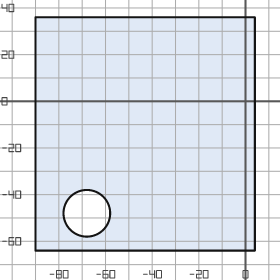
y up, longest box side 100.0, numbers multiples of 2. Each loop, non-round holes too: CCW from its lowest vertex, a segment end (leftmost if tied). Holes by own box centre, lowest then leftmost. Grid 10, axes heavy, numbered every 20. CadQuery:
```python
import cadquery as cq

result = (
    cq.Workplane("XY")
    .moveTo(-90.0, -64.0)
    .lineTo(4.0, -64.0)
    .lineTo(4.0, 36.0)
    .lineTo(-90.0, 36.0)
    .close()
    .moveTo(-68.0, -48.0)
    .circle(10.0)
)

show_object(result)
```